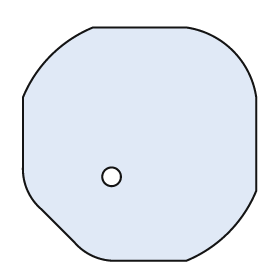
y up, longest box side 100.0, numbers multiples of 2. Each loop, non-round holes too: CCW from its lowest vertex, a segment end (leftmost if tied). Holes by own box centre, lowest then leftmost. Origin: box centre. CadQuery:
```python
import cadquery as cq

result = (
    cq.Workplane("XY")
    .moveTo(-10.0, -50.0)
    .lineTo(20.0, -50.0)
    .threePointArc((38.0, -38.0), (50.0, -20.0))
    .lineTo(50.0, 20.0)
    .threePointArc((40.0, 40.0), (20.0, 50.0))
    .lineTo(-20.0, 50.0)
    .threePointArc((-38.0, 38.0), (-50.0, 20.0))
    .lineTo(-50.0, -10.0)
    .threePointArc((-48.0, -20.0), (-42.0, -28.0))
    .lineTo(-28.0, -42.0)
    .threePointArc((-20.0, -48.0), (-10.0, -50.0))
    .close()
    .moveTo(-12.0, -14.0)
    .circle(4.0)
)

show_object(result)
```